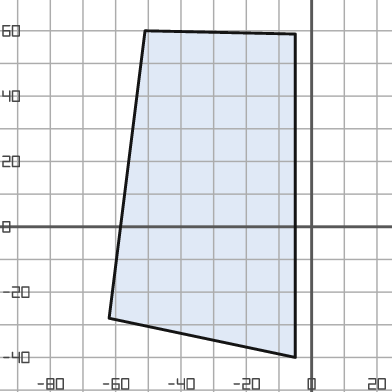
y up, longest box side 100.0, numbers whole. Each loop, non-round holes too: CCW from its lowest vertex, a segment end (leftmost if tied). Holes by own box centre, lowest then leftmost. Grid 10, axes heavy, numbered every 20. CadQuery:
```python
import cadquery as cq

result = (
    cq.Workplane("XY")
    .moveTo(-5.0, -40.0)
    .lineTo(-5.0, 59.0)
    .lineTo(-51.0, 60.0)
    .lineTo(-62.0, -28.0)
    .close()
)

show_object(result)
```